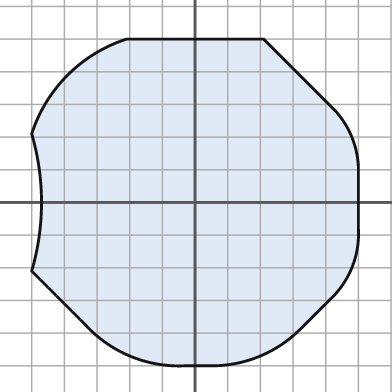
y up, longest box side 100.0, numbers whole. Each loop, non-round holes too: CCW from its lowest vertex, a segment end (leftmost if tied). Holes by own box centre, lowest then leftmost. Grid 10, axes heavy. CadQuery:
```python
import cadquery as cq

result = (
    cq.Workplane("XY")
    .moveTo(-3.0, -50.0)
    .lineTo(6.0, -50.0)
    .threePointArc((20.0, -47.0), (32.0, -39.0))
    .lineTo(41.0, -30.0)
    .threePointArc((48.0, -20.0), (50.0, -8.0))
    .lineTo(50.0, 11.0)
    .threePointArc((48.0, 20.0), (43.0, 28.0))
    .lineTo(21.0, 50.0)
    .lineTo(-21.0, 50.0)
    .threePointArc((-39.0, 39.0), (-50.0, 21.0))
    .threePointArc((-47.0, 0.0), (-50.0, -21.0))
    .lineTo(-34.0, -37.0)
    .threePointArc((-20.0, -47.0), (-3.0, -50.0))
    .close()
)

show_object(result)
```